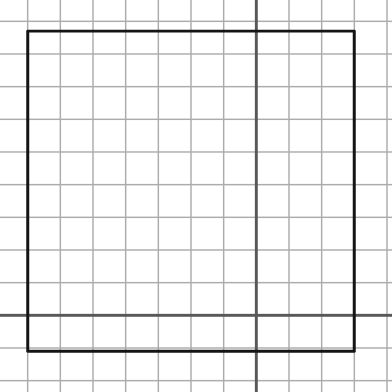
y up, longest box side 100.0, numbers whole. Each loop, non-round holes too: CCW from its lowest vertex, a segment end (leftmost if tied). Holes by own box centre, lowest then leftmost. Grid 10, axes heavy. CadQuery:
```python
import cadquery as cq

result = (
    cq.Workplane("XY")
    .moveTo(-70.0, -11.0)
    .lineTo(30.0, -11.0)
    .lineTo(30.0, 87.0)
    .lineTo(-70.0, 87.0)
    .close()
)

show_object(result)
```